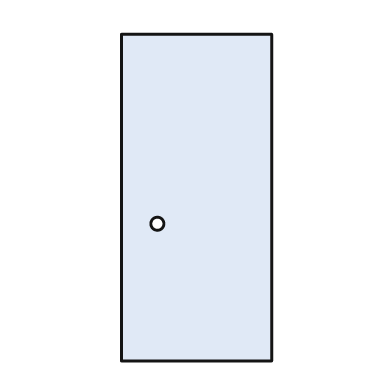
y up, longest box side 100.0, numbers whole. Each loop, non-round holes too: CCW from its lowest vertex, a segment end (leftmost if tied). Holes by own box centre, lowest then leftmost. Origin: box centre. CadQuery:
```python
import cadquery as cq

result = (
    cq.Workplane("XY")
    .moveTo(-23.0, -50.0)
    .lineTo(23.0, -50.0)
    .lineTo(23.0, 50.0)
    .lineTo(-23.0, 50.0)
    .close()
    .moveTo(-12.0, -8.0)
    .circle(2.0)
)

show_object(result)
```